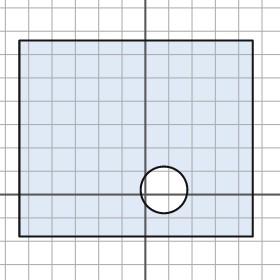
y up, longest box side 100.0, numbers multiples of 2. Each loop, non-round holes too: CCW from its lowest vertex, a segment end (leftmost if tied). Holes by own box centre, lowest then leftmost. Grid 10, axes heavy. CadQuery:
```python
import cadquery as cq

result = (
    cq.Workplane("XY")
    .moveTo(-54.0, -18.0)
    .lineTo(46.0, -18.0)
    .lineTo(46.0, 66.0)
    .lineTo(-54.0, 66.0)
    .close()
    .moveTo(8.0, 2.0)
    .circle(10.0)
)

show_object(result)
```